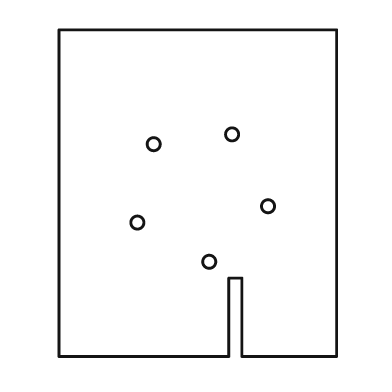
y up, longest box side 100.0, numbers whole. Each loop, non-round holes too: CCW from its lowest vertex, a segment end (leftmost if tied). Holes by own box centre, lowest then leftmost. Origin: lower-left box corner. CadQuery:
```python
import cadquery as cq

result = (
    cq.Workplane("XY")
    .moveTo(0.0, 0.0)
    .lineTo(52.0, 0.0)
    .lineTo(52.0, 24.0)
    .lineTo(56.0, 24.0)
    .lineTo(56.0, 0.0)
    .lineTo(85.0, 0.0)
    .lineTo(85.0, 100.0)
    .lineTo(0.0, 100.0)
    .close()
    .moveTo(46.0, 29.0)
    .circle(2.0)
    .moveTo(24.0, 41.0)
    .circle(2.0)
    .moveTo(64.0, 46.0)
    .circle(2.0)
    .moveTo(29.0, 65.0)
    .circle(2.0)
    .moveTo(53.0, 68.0)
    .circle(2.0)
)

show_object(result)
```